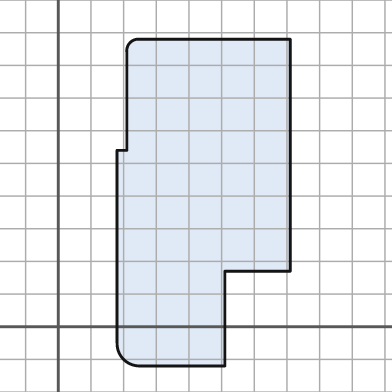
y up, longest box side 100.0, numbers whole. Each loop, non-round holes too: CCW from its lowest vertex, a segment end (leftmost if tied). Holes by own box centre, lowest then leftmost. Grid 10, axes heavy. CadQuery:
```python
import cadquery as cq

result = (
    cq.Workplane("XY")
    .moveTo(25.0, -12.0)
    .lineTo(51.0, -12.0)
    .lineTo(51.0, 17.0)
    .lineTo(71.0, 17.0)
    .lineTo(71.0, 88.0)
    .lineTo(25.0, 88.0)
    .threePointArc((22.0, 87.0), (21.0, 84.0))
    .lineTo(21.0, 54.0)
    .lineTo(18.0, 54.0)
    .lineTo(18.0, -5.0)
    .threePointArc((20.0, -10.0), (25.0, -12.0))
    .close()
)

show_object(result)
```